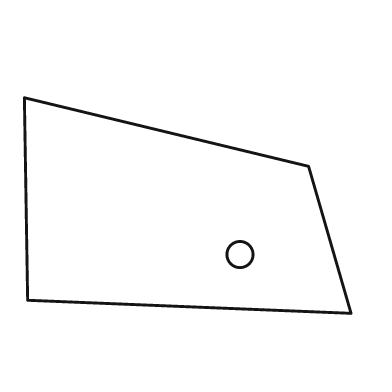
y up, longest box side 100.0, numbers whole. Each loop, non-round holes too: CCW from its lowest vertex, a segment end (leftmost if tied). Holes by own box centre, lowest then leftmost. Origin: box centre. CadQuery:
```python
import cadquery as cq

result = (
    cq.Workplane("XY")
    .moveTo(50.0, -33.0)
    .lineTo(37.0, 12.0)
    .lineTo(-50.0, 33.0)
    .lineTo(-49.0, -29.0)
    .close()
    .moveTo(16.0, -15.0)
    .circle(4.0)
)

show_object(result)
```